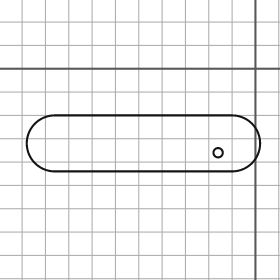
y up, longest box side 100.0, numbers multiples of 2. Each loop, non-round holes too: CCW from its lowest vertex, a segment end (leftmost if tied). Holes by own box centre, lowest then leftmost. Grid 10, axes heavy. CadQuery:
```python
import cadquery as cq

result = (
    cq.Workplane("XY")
    .moveTo(-86.0, -44.0)
    .lineTo(-10.0, -44.0)
    .threePointArc((2.0, -32.0), (-10.0, -20.0))
    .lineTo(-86.0, -20.0)
    .threePointArc((-98.0, -32.0), (-86.0, -44.0))
    .close()
    .moveTo(-16.0, -36.0)
    .circle(2.0)
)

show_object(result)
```